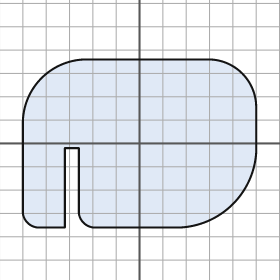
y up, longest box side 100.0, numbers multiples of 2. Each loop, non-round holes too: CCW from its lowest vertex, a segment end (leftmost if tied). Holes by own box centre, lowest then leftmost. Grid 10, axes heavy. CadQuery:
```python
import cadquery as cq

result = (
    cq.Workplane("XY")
    .moveTo(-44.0, -36.0)
    .lineTo(-32.0, -36.0)
    .lineTo(-32.0, -2.0)
    .lineTo(-26.0, -2.0)
    .lineTo(-26.0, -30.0)
    .threePointArc((-24.0, -34.0), (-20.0, -36.0))
    .lineTo(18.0, -36.0)
    .threePointArc((40.0, -26.0), (50.0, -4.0))
    .lineTo(50.0, 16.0)
    .threePointArc((44.0, 30.0), (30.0, 36.0))
    .lineTo(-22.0, 36.0)
    .threePointArc((-42.0, 28.0), (-50.0, 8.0))
    .lineTo(-50.0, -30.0)
    .threePointArc((-48.0, -34.0), (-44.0, -36.0))
    .close()
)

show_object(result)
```